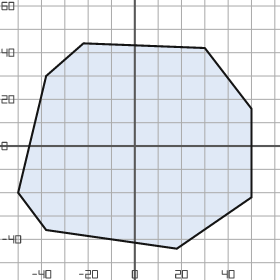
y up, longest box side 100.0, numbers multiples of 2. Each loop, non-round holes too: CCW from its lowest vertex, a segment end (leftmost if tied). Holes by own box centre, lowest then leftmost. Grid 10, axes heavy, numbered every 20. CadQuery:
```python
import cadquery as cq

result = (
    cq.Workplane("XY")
    .moveTo(18.0, -44.0)
    .lineTo(50.0, -22.0)
    .lineTo(50.0, 16.0)
    .lineTo(30.0, 42.0)
    .lineTo(-22.0, 44.0)
    .lineTo(-38.0, 30.0)
    .lineTo(-50.0, -20.0)
    .lineTo(-38.0, -36.0)
    .close()
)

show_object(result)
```